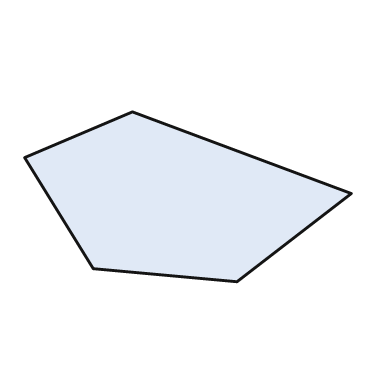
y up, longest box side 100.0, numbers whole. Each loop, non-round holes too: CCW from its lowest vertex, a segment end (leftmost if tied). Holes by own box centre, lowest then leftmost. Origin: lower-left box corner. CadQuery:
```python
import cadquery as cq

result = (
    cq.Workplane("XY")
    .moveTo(65.0, 0.0)
    .lineTo(100.0, 27.0)
    .lineTo(33.0, 52.0)
    .lineTo(0.0, 38.0)
    .lineTo(21.0, 4.0)
    .close()
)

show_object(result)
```